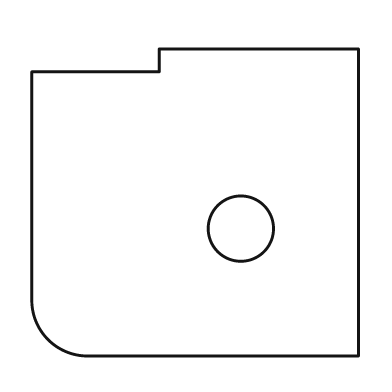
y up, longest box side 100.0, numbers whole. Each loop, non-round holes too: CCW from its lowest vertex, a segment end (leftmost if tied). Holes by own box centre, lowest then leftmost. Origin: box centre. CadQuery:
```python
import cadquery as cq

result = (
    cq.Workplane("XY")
    .moveTo(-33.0, -47.0)
    .lineTo(50.0, -47.0)
    .lineTo(50.0, 47.0)
    .lineTo(-11.0, 47.0)
    .lineTo(-11.0, 40.0)
    .lineTo(-50.0, 40.0)
    .lineTo(-50.0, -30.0)
    .threePointArc((-45.0, -42.0), (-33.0, -47.0))
    .close()
    .moveTo(14.0, -8.0)
    .circle(10.0)
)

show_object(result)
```